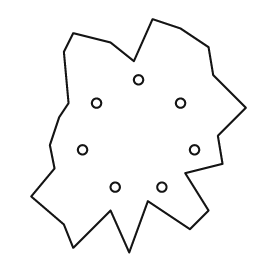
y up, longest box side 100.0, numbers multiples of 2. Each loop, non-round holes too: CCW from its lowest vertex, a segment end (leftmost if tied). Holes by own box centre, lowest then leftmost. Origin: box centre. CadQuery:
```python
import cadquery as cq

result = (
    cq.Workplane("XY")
    .moveTo(-4.0, -50.0)
    .lineTo(4.0, -28.0)
    .lineTo(22.0, -40.0)
    .lineTo(30.0, -32.0)
    .lineTo(20.0, -16.0)
    .lineTo(36.0, -12.0)
    .lineTo(34.0, 0.0)
    .lineTo(46.0, 12.0)
    .lineTo(32.0, 26.0)
    .lineTo(30.0, 38.0)
    .lineTo(18.0, 46.0)
    .lineTo(6.0, 50.0)
    .lineTo(-2.0, 32.0)
    .lineTo(-12.0, 40.0)
    .lineTo(-28.0, 44.0)
    .lineTo(-32.0, 36.0)
    .lineTo(-30.0, 14.0)
    .lineTo(-34.0, 8.0)
    .lineTo(-38.0, -4.0)
    .lineTo(-36.0, -14.0)
    .lineTo(-46.0, -26.0)
    .lineTo(-32.0, -38.0)
    .lineTo(-28.0, -48.0)
    .lineTo(-12.0, -32.0)
    .close()
    .moveTo(-10.0, -22.0)
    .circle(2.0)
    .moveTo(10.0, -22.0)
    .circle(2.0)
    .moveTo(-24.0, -6.0)
    .circle(2.0)
    .moveTo(24.0, -6.0)
    .circle(2.0)
    .moveTo(-18.0, 14.0)
    .circle(2.0)
    .moveTo(18.0, 14.0)
    .circle(2.0)
    .moveTo(0.0, 24.0)
    .circle(2.0)
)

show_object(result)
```